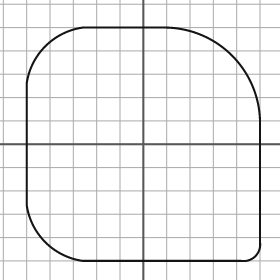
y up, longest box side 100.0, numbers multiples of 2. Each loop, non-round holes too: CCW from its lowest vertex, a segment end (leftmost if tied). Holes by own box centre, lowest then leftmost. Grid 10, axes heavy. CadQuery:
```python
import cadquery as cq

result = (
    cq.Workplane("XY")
    .moveTo(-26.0, -50.0)
    .lineTo(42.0, -50.0)
    .threePointArc((48.0, -48.0), (50.0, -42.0))
    .lineTo(50.0, 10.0)
    .threePointArc((38.0, 38.0), (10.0, 50.0))
    .lineTo(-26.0, 50.0)
    .threePointArc((-42.0, 42.0), (-50.0, 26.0))
    .lineTo(-50.0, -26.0)
    .threePointArc((-42.0, -42.0), (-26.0, -50.0))
    .close()
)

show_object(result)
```